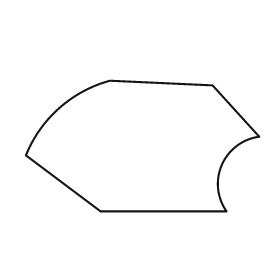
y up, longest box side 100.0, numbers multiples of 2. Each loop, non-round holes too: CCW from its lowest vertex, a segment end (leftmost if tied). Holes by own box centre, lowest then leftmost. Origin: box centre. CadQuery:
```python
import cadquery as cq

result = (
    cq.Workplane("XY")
    .moveTo(-18.0, -28.0)
    .lineTo(36.0, -28.0)
    .threePointArc((34.0, -8.0), (50.0, 4.0))
    .lineTo(30.0, 26.0)
    .lineTo(-14.0, 28.0)
    .threePointArc((-36.0, 16.0), (-50.0, -4.0))
    .close()
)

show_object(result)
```